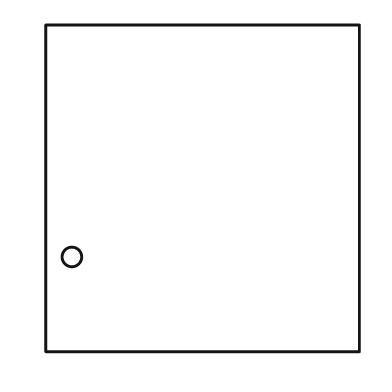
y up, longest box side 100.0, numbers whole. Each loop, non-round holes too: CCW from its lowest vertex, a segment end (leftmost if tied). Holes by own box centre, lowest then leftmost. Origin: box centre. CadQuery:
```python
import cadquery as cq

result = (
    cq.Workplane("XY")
    .moveTo(-48.0, -50.0)
    .lineTo(48.0, -50.0)
    .lineTo(48.0, 50.0)
    .lineTo(-48.0, 50.0)
    .close()
    .moveTo(-40.0, -21.0)
    .circle(3.0)
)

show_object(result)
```